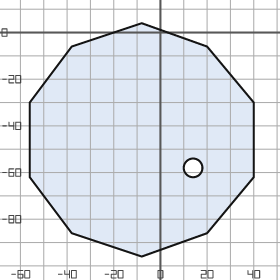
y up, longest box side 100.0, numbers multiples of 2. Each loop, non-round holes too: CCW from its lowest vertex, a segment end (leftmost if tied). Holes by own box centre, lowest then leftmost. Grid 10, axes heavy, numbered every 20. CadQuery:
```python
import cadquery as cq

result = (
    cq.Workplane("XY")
    .moveTo(-8.0, -96.0)
    .lineTo(20.0, -86.0)
    .lineTo(40.0, -62.0)
    .lineTo(40.0, -30.0)
    .lineTo(20.0, -6.0)
    .lineTo(-8.0, 4.0)
    .lineTo(-38.0, -6.0)
    .lineTo(-56.0, -30.0)
    .lineTo(-56.0, -62.0)
    .lineTo(-38.0, -86.0)
    .close()
    .moveTo(14.0, -58.0)
    .circle(4.0)
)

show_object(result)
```